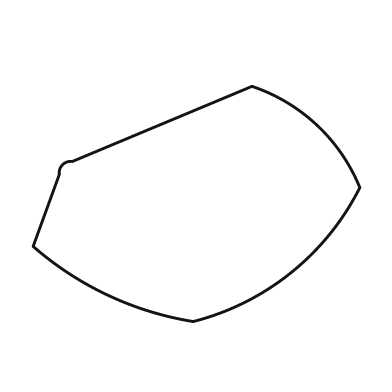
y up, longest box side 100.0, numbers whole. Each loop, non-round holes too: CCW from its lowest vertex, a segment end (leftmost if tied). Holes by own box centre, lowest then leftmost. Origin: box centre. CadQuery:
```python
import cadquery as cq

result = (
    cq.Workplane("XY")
    .moveTo(-1.0, -36.0)
    .threePointArc((29.0, -21.0), (50.0, 5.0))
    .threePointArc((37.0, 24.0), (17.0, 36.0))
    .lineTo(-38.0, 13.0)
    .threePointArc((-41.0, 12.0), (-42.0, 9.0))
    .lineTo(-50.0, -13.0)
    .threePointArc((-27.0, -28.0), (-1.0, -36.0))
    .close()
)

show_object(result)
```